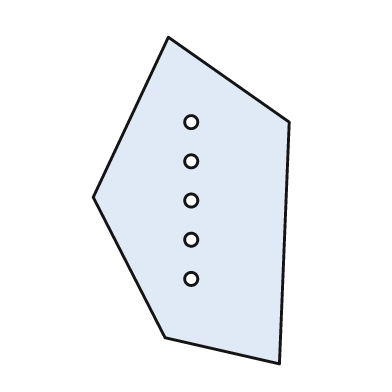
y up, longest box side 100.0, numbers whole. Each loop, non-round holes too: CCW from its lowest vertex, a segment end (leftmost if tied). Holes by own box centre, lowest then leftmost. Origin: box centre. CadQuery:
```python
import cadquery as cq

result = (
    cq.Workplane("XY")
    .moveTo(27.0, -50.0)
    .lineTo(30.0, 24.0)
    .lineTo(-7.0, 50.0)
    .lineTo(-30.0, 1.0)
    .lineTo(-8.0, -42.0)
    .close()
    .moveTo(0.0, -24.0)
    .circle(2.0)
    .moveTo(0.0, -12.0)
    .circle(2.0)
    .moveTo(0.0, 0.0)
    .circle(2.0)
    .moveTo(0.0, 12.0)
    .circle(2.0)
    .moveTo(0.0, 24.0)
    .circle(2.0)
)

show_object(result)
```